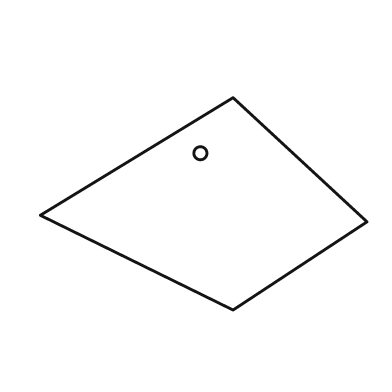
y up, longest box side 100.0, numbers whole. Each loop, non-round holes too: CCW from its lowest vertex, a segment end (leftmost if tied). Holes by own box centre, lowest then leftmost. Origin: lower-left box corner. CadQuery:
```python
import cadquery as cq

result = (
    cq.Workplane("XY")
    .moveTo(59.0, 0.0)
    .lineTo(100.0, 27.0)
    .lineTo(59.0, 65.0)
    .lineTo(0.0, 29.0)
    .close()
    .moveTo(49.0, 48.0)
    .circle(2.0)
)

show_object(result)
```